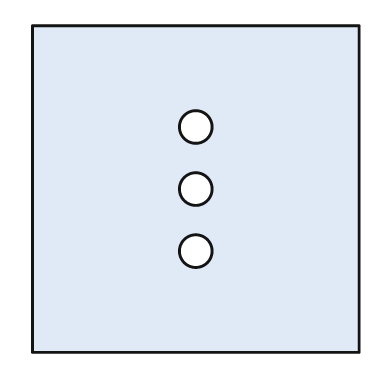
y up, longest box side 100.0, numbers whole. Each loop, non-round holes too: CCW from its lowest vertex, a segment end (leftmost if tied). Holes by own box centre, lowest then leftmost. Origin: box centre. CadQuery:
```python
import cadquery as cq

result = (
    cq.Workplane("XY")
    .moveTo(-50.0, -50.0)
    .lineTo(50.0, -50.0)
    .lineTo(50.0, 50.0)
    .lineTo(-50.0, 50.0)
    .close()
    .moveTo(0.0, -19.0)
    .circle(5.0)
    .moveTo(0.0, 0.0)
    .circle(5.0)
    .moveTo(0.0, 19.0)
    .circle(5.0)
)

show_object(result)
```